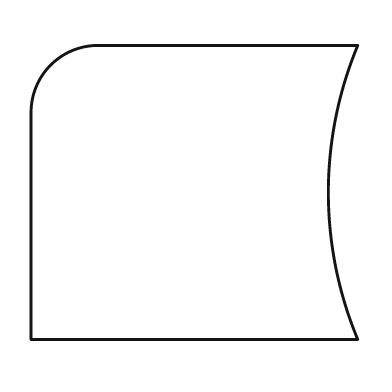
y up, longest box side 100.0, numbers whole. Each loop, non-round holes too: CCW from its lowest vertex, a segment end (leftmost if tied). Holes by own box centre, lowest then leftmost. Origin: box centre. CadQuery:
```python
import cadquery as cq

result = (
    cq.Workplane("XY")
    .moveTo(-50.0, -45.0)
    .lineTo(50.0, -45.0)
    .threePointArc((41.0, 0.0), (50.0, 45.0))
    .lineTo(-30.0, 45.0)
    .threePointArc((-44.0, 39.0), (-50.0, 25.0))
    .close()
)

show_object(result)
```